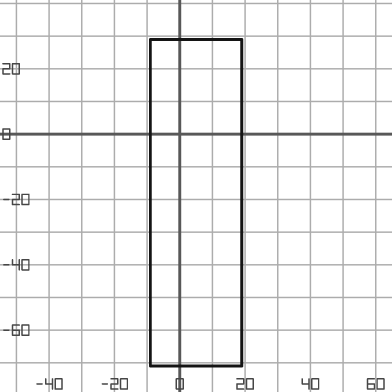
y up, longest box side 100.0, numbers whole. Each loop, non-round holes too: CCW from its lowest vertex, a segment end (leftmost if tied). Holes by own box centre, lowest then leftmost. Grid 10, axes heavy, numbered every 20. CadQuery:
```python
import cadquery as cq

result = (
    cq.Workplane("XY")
    .moveTo(-9.0, -71.0)
    .lineTo(19.0, -71.0)
    .lineTo(19.0, 29.0)
    .lineTo(-9.0, 29.0)
    .close()
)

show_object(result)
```